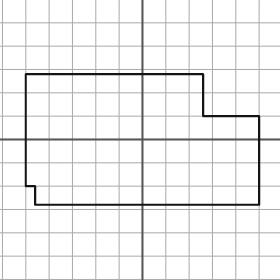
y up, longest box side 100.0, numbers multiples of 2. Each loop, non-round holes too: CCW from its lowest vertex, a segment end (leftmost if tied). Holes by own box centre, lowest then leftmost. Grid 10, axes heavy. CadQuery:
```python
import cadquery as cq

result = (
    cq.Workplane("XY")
    .moveTo(-46.0, -28.0)
    .lineTo(50.0, -28.0)
    .lineTo(50.0, 10.0)
    .lineTo(26.0, 10.0)
    .lineTo(26.0, 28.0)
    .lineTo(-50.0, 28.0)
    .lineTo(-50.0, -20.0)
    .lineTo(-46.0, -20.0)
    .close()
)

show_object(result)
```